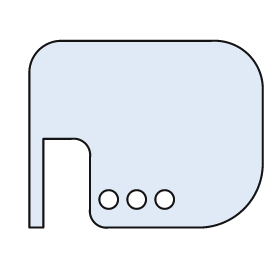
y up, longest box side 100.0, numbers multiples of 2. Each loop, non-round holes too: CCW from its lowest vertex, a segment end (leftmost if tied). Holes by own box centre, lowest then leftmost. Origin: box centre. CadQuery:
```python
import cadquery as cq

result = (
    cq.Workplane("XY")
    .moveTo(-50.0, -40.0)
    .lineTo(-44.0, -40.0)
    .lineTo(-44.0, -2.0)
    .lineTo(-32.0, -2.0)
    .threePointArc((-26.0, -4.0), (-24.0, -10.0))
    .lineTo(-24.0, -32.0)
    .threePointArc((-22.0, -38.0), (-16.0, -40.0))
    .lineTo(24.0, -40.0)
    .threePointArc((42.0, -32.0), (50.0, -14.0))
    .lineTo(50.0, 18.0)
    .threePointArc((44.0, 34.0), (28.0, 40.0))
    .lineTo(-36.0, 40.0)
    .threePointArc((-46.0, 36.0), (-50.0, 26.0))
    .close()
    .moveTo(-16.0, -28.0)
    .circle(4.0)
    .moveTo(-4.0, -28.0)
    .circle(4.0)
    .moveTo(8.0, -28.0)
    .circle(4.0)
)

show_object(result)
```